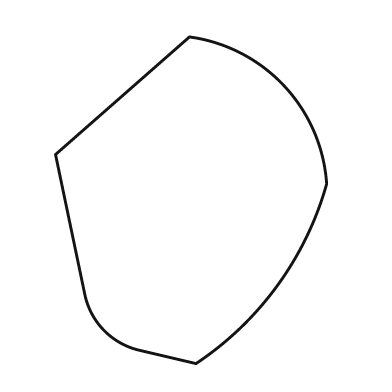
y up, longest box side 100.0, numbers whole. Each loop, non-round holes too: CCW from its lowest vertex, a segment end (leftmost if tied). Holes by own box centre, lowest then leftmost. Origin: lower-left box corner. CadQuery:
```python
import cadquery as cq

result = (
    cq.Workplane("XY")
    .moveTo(43.0, 0.0)
    .threePointArc((68.0, 24.0), (83.0, 55.0))
    .threePointArc((70.0, 85.0), (41.0, 100.0))
    .lineTo(0.0, 64.0)
    .lineTo(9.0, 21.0)
    .threePointArc((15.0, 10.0), (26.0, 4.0))
    .close()
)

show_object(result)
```